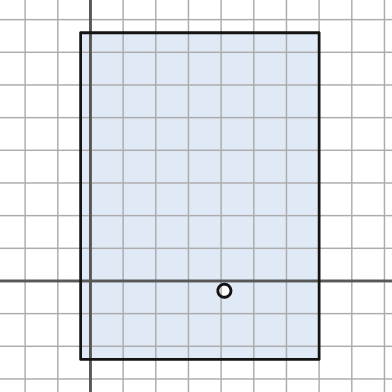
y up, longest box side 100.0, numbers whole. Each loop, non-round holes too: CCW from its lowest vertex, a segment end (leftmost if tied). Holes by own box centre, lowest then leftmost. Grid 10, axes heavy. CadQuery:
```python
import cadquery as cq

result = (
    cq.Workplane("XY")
    .moveTo(-3.0, -24.0)
    .lineTo(70.0, -24.0)
    .lineTo(70.0, 76.0)
    .lineTo(-3.0, 76.0)
    .close()
    .moveTo(41.0, -3.0)
    .circle(2.0)
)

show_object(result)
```